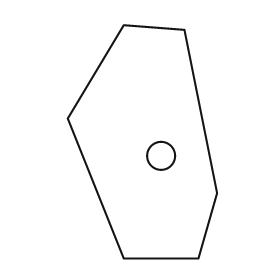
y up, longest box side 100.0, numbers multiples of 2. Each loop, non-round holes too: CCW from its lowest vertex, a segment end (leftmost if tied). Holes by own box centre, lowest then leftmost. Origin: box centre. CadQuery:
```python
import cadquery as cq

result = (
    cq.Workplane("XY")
    .moveTo(-8.0, -50.0)
    .lineTo(24.0, -50.0)
    .lineTo(32.0, -22.0)
    .lineTo(18.0, 48.0)
    .lineTo(-8.0, 50.0)
    .lineTo(-32.0, 10.0)
    .close()
    .moveTo(8.0, -6.0)
    .circle(6.0)
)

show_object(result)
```